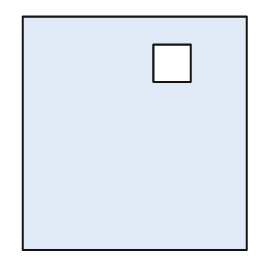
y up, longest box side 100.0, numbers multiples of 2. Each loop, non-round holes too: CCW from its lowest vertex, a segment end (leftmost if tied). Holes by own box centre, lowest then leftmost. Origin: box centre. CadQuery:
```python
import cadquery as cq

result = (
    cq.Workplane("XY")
    .moveTo(-48.0, -50.0)
    .lineTo(48.0, -50.0)
    .lineTo(48.0, 50.0)
    .lineTo(-48.0, 50.0)
    .close()
    .moveTo(8.0, 22.0)
    .lineTo(24.0, 22.0)
    .lineTo(24.0, 38.0)
    .lineTo(8.0, 38.0)
    .close()
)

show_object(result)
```